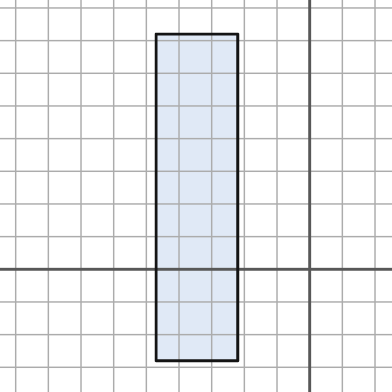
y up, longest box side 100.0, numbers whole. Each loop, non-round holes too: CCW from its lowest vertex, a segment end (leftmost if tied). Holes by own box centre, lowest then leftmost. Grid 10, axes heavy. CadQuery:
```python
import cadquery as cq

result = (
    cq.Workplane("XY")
    .moveTo(-47.0, -28.0)
    .lineTo(-22.0, -28.0)
    .lineTo(-22.0, 72.0)
    .lineTo(-47.0, 72.0)
    .close()
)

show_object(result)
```